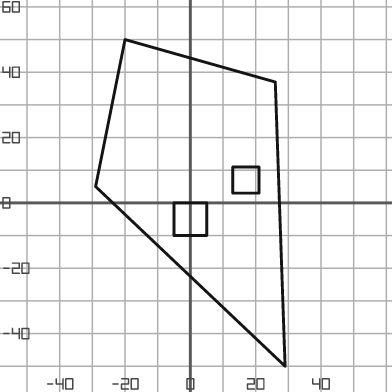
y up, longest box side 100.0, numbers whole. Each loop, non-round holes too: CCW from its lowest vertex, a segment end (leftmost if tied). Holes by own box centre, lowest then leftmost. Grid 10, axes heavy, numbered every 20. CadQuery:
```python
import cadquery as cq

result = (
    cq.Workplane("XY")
    .moveTo(29.0, -50.0)
    .lineTo(26.0, 37.0)
    .lineTo(-20.0, 50.0)
    .lineTo(-29.0, 5.0)
    .close()
    .moveTo(-5.0, -10.0)
    .lineTo(5.0, -10.0)
    .lineTo(5.0, 0.0)
    .lineTo(-5.0, 0.0)
    .close()
    .moveTo(13.0, 3.0)
    .lineTo(21.0, 3.0)
    .lineTo(21.0, 11.0)
    .lineTo(13.0, 11.0)
    .close()
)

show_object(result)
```